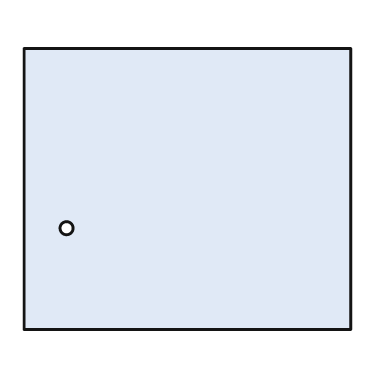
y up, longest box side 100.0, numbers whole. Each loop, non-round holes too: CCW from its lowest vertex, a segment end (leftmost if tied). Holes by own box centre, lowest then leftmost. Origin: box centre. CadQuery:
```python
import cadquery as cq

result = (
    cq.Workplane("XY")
    .moveTo(-50.0, -43.0)
    .lineTo(50.0, -43.0)
    .lineTo(50.0, 43.0)
    .lineTo(-50.0, 43.0)
    .close()
    .moveTo(-37.0, -12.0)
    .circle(2.0)
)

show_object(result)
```